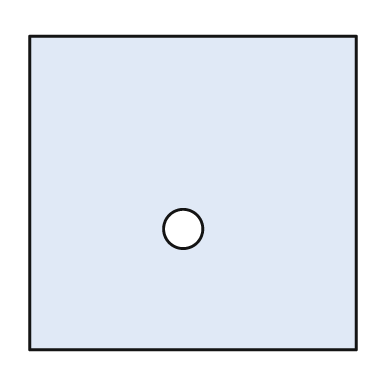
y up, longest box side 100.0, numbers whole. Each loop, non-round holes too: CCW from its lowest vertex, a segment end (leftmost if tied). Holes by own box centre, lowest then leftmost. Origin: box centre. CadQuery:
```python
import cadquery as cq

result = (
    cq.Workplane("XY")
    .moveTo(-50.0, -48.0)
    .lineTo(50.0, -48.0)
    .lineTo(50.0, 48.0)
    .lineTo(-50.0, 48.0)
    .close()
    .moveTo(-3.0, -11.0)
    .circle(6.0)
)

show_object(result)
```